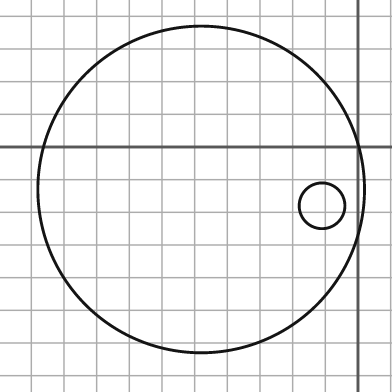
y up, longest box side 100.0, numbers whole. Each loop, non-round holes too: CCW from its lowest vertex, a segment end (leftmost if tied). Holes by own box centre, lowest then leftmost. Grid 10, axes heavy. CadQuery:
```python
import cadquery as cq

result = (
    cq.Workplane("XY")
    .moveTo(-48.0, -13.0)
    .circle(50.0)
    .moveTo(-11.0, -18.0)
    .circle(7.0)
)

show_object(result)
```